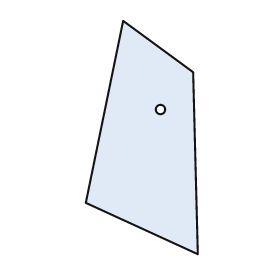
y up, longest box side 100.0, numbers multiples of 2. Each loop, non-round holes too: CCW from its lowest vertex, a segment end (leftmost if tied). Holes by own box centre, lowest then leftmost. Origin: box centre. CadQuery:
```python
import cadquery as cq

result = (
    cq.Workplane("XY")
    .moveTo(24.0, -50.0)
    .lineTo(22.0, 28.0)
    .lineTo(-8.0, 50.0)
    .lineTo(-24.0, -28.0)
    .close()
    .moveTo(8.0, 12.0)
    .circle(2.0)
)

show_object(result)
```